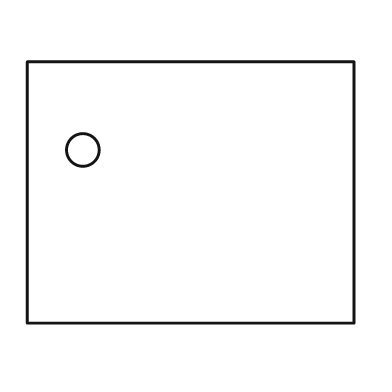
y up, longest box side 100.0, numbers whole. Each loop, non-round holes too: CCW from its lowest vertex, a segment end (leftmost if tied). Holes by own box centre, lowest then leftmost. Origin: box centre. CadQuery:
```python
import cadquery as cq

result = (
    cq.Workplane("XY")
    .moveTo(-50.0, -40.0)
    .lineTo(50.0, -40.0)
    .lineTo(50.0, 40.0)
    .lineTo(-50.0, 40.0)
    .close()
    .moveTo(-33.0, 13.0)
    .circle(5.0)
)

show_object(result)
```